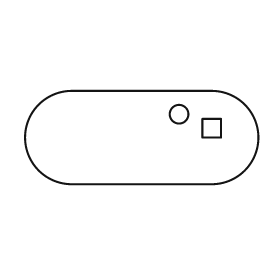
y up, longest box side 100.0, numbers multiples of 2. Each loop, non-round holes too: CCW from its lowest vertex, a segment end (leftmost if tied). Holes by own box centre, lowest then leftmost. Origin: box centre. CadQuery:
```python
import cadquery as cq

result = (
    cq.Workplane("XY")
    .moveTo(-30.0, -20.0)
    .lineTo(30.0, -20.0)
    .threePointArc((50.0, 0.0), (30.0, 20.0))
    .lineTo(-30.0, 20.0)
    .threePointArc((-50.0, 0.0), (-30.0, -20.0))
    .close()
    .moveTo(26.0, 0.0)
    .lineTo(34.0, 0.0)
    .lineTo(34.0, 8.0)
    .lineTo(26.0, 8.0)
    .close()
    .moveTo(16.0, 10.0)
    .circle(4.0)
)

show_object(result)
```